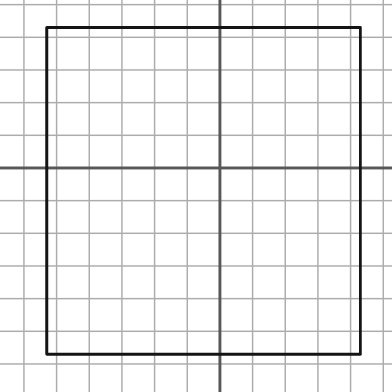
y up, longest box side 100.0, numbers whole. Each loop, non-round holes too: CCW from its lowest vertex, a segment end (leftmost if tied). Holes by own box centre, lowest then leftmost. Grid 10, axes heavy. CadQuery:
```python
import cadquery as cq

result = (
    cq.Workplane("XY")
    .moveTo(-53.0, -57.0)
    .lineTo(43.0, -57.0)
    .lineTo(43.0, 43.0)
    .lineTo(-53.0, 43.0)
    .close()
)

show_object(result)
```